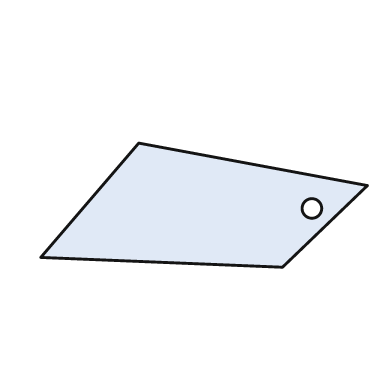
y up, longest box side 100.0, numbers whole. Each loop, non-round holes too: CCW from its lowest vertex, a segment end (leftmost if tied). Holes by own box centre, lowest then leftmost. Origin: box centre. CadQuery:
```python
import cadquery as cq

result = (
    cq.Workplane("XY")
    .moveTo(24.0, -19.0)
    .lineTo(50.0, 6.0)
    .lineTo(-20.0, 19.0)
    .lineTo(-50.0, -16.0)
    .close()
    .moveTo(33.0, -1.0)
    .circle(3.0)
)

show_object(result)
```